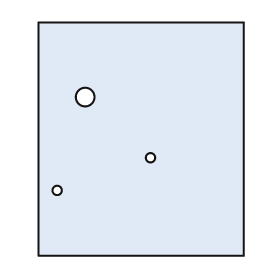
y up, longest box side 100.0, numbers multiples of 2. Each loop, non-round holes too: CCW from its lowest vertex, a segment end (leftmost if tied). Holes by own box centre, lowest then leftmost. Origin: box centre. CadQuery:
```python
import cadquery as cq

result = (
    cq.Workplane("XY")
    .moveTo(-44.0, -50.0)
    .lineTo(44.0, -50.0)
    .lineTo(44.0, 50.0)
    .lineTo(-44.0, 50.0)
    .close()
    .moveTo(-36.0, -22.0)
    .circle(2.0)
    .moveTo(4.0, -8.0)
    .circle(2.0)
    .moveTo(-24.0, 18.0)
    .circle(4.0)
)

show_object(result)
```